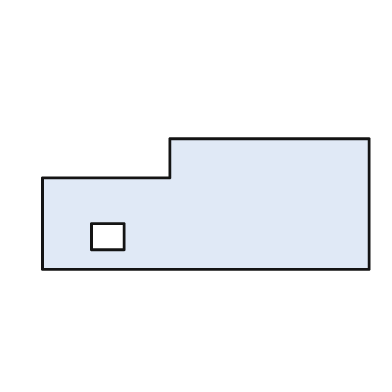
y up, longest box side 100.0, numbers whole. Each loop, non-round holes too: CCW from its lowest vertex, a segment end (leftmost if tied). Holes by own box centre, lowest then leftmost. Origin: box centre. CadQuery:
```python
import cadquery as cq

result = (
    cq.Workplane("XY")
    .moveTo(-50.0, -20.0)
    .lineTo(50.0, -20.0)
    .lineTo(50.0, 20.0)
    .lineTo(-11.0, 20.0)
    .lineTo(-11.0, 8.0)
    .lineTo(-50.0, 8.0)
    .close()
    .moveTo(-35.0, -14.0)
    .lineTo(-25.0, -14.0)
    .lineTo(-25.0, -6.0)
    .lineTo(-35.0, -6.0)
    .close()
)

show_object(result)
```